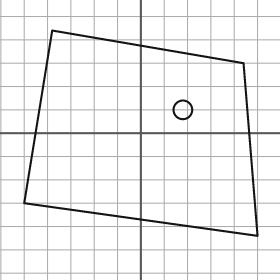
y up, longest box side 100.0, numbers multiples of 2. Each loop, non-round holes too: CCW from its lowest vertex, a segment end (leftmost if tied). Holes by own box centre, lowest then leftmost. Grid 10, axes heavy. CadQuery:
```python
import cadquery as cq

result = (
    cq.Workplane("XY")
    .moveTo(50.0, -44.0)
    .lineTo(44.0, 30.0)
    .lineTo(-38.0, 44.0)
    .lineTo(-50.0, -30.0)
    .close()
    .moveTo(18.0, 10.0)
    .circle(4.0)
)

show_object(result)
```